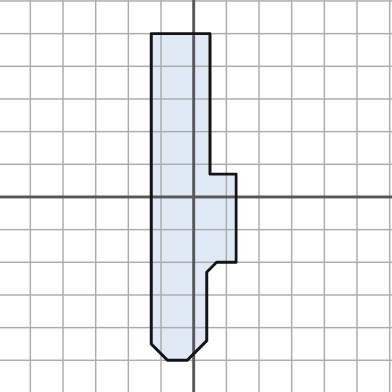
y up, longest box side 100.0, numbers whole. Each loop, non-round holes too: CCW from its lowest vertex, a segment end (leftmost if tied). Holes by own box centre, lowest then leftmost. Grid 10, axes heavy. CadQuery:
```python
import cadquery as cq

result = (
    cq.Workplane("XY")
    .moveTo(-8.0, -50.0)
    .lineTo(-2.0, -50.0)
    .lineTo(4.0, -44.0)
    .lineTo(4.0, -23.0)
    .lineTo(7.0, -20.0)
    .lineTo(13.0, -20.0)
    .lineTo(13.0, 7.0)
    .lineTo(5.0, 7.0)
    .lineTo(5.0, 50.0)
    .lineTo(-13.0, 50.0)
    .lineTo(-13.0, -45.0)
    .close()
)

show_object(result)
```